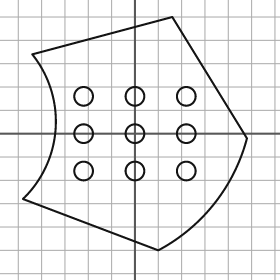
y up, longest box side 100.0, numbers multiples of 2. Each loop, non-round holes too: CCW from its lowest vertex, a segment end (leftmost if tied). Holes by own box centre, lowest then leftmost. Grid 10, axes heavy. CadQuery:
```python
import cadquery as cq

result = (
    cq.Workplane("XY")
    .moveTo(10.0, -50.0)
    .threePointArc((34.0, -30.0), (48.0, -2.0))
    .lineTo(16.0, 50.0)
    .lineTo(-44.0, 34.0)
    .threePointArc((-34.0, 2.0), (-48.0, -28.0))
    .close()
    .moveTo(-22.0, -16.0)
    .circle(4.0)
    .moveTo(0.0, -16.0)
    .circle(4.0)
    .moveTo(22.0, -16.0)
    .circle(4.0)
    .moveTo(-22.0, 0.0)
    .circle(4.0)
    .moveTo(0.0, 0.0)
    .circle(4.0)
    .moveTo(22.0, 0.0)
    .circle(4.0)
    .moveTo(-22.0, 16.0)
    .circle(4.0)
    .moveTo(0.0, 16.0)
    .circle(4.0)
    .moveTo(22.0, 16.0)
    .circle(4.0)
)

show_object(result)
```